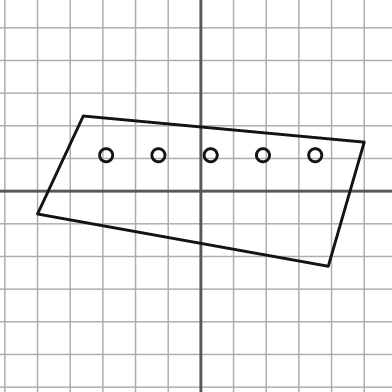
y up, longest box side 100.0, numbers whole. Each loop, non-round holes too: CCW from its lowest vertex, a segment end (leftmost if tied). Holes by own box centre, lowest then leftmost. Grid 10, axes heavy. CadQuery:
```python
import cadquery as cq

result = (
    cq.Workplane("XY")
    .moveTo(39.0, -23.0)
    .lineTo(50.0, 15.0)
    .lineTo(-36.0, 23.0)
    .lineTo(-50.0, -7.0)
    .close()
    .moveTo(-29.0, 11.0)
    .circle(2.0)
    .moveTo(-13.0, 11.0)
    .circle(2.0)
    .moveTo(3.0, 11.0)
    .circle(2.0)
    .moveTo(19.0, 11.0)
    .circle(2.0)
    .moveTo(35.0, 11.0)
    .circle(2.0)
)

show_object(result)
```